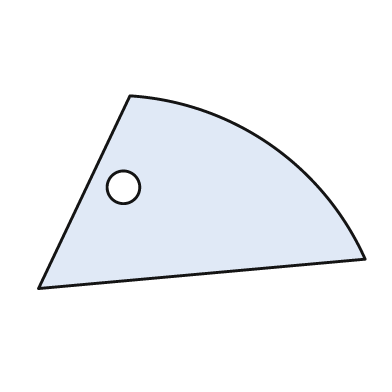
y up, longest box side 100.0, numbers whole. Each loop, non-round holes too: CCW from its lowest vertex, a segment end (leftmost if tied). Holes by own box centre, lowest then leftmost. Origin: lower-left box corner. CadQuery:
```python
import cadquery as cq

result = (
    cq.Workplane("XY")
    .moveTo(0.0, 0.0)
    .lineTo(100.0, 9.0)
    .threePointArc((71.0, 44.0), (28.0, 59.0))
    .close()
    .moveTo(26.0, 31.0)
    .circle(5.0)
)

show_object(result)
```